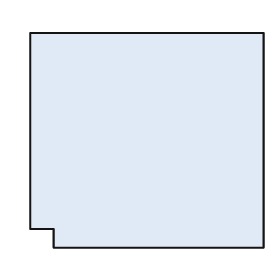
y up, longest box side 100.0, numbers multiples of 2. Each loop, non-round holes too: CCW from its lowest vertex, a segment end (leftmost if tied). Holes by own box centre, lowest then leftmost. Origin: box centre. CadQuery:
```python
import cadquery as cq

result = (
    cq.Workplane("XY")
    .moveTo(-40.0, -46.0)
    .lineTo(50.0, -46.0)
    .lineTo(50.0, 46.0)
    .lineTo(-50.0, 46.0)
    .lineTo(-50.0, -38.0)
    .lineTo(-40.0, -38.0)
    .close()
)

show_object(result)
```